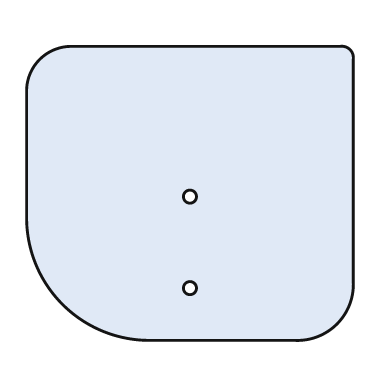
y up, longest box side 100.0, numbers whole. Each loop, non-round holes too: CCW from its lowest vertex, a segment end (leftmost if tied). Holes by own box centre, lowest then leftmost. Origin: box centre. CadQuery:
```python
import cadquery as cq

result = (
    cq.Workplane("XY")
    .moveTo(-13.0, -45.0)
    .lineTo(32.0, -45.0)
    .threePointArc((45.0, -40.0), (50.0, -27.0))
    .lineTo(50.0, 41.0)
    .threePointArc((49.0, 44.0), (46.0, 45.0))
    .lineTo(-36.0, 45.0)
    .threePointArc((-46.0, 41.0), (-50.0, 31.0))
    .lineTo(-50.0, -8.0)
    .threePointArc((-39.0, -34.0), (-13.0, -45.0))
    .close()
    .moveTo(0.0, -29.0)
    .circle(2.0)
    .moveTo(0.0, -1.0)
    .circle(2.0)
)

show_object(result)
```